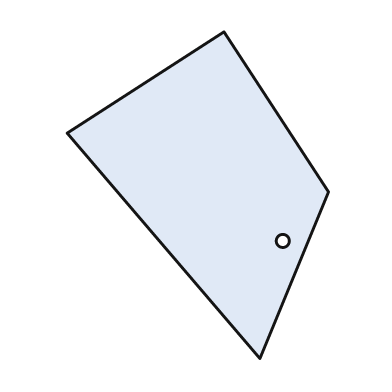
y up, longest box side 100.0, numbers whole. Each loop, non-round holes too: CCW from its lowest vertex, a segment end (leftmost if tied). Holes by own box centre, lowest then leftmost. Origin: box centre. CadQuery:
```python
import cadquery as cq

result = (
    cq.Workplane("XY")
    .moveTo(19.0, -50.0)
    .lineTo(40.0, 1.0)
    .lineTo(8.0, 50.0)
    .lineTo(-40.0, 19.0)
    .close()
    .moveTo(26.0, -14.0)
    .circle(2.0)
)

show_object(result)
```